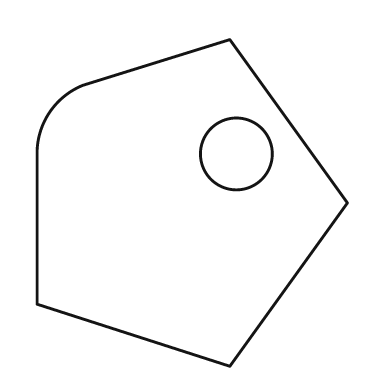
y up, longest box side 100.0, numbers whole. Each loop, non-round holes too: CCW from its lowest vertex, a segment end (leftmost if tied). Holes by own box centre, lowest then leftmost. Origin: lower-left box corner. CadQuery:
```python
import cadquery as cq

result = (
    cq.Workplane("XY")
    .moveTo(59.0, 0.0)
    .lineTo(95.0, 50.0)
    .lineTo(59.0, 100.0)
    .lineTo(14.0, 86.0)
    .threePointArc((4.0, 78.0), (0.0, 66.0))
    .lineTo(0.0, 19.0)
    .close()
    .moveTo(61.0, 65.0)
    .circle(11.0)
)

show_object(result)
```